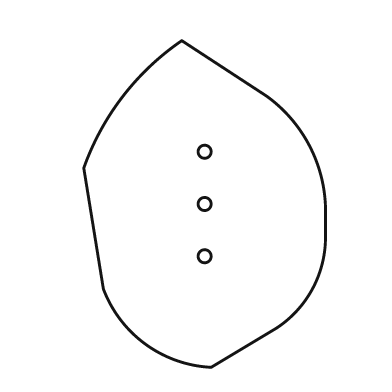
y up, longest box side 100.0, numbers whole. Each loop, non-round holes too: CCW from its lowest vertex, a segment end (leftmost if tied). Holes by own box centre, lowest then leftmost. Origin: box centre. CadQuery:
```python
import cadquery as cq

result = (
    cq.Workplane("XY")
    .moveTo(2.0, -50.0)
    .lineTo(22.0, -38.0)
    .threePointArc((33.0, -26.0), (37.0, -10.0))
    .lineTo(37.0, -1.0)
    .threePointArc((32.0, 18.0), (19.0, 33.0))
    .lineTo(-7.0, 50.0)
    .threePointArc((-25.0, 33.0), (-37.0, 11.0))
    .lineTo(-31.0, -26.0)
    .threePointArc((-18.0, -43.0), (2.0, -50.0))
    .close()
    .moveTo(0.0, -16.0)
    .circle(2.0)
    .moveTo(0.0, 0.0)
    .circle(2.0)
    .moveTo(0.0, 16.0)
    .circle(2.0)
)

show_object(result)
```